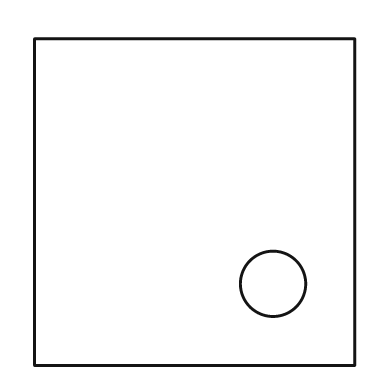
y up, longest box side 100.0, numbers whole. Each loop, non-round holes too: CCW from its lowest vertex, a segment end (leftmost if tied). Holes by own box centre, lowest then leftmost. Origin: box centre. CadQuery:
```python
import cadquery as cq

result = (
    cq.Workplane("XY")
    .moveTo(-49.0, -50.0)
    .lineTo(49.0, -50.0)
    .lineTo(49.0, 50.0)
    .lineTo(-49.0, 50.0)
    .close()
    .moveTo(24.0, -25.0)
    .circle(10.0)
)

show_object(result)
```